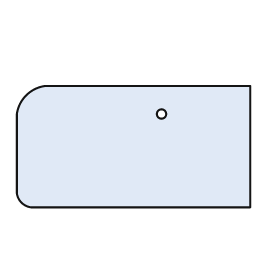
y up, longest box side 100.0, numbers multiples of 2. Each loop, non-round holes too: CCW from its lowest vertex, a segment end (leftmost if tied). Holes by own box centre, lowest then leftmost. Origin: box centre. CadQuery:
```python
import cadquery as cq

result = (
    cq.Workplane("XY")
    .moveTo(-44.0, -26.0)
    .lineTo(50.0, -26.0)
    .lineTo(50.0, 26.0)
    .lineTo(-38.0, 26.0)
    .threePointArc((-46.0, 22.0), (-50.0, 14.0))
    .lineTo(-50.0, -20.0)
    .threePointArc((-48.0, -24.0), (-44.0, -26.0))
    .close()
    .moveTo(12.0, 14.0)
    .circle(2.0)
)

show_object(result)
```